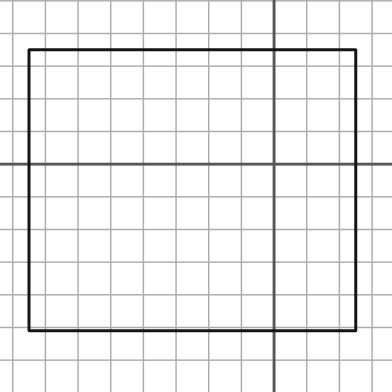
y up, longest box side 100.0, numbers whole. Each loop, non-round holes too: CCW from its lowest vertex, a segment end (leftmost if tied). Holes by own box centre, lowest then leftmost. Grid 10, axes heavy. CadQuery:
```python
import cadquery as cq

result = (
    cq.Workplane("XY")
    .moveTo(-75.0, -51.0)
    .lineTo(25.0, -51.0)
    .lineTo(25.0, 35.0)
    .lineTo(-75.0, 35.0)
    .close()
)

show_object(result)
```